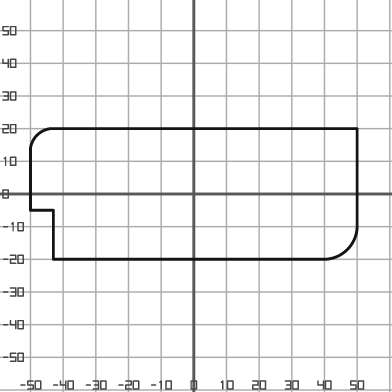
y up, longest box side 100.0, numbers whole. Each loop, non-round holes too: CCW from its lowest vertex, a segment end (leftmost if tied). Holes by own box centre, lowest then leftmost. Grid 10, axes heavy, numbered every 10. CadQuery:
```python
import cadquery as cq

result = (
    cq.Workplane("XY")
    .moveTo(-43.0, -20.0)
    .lineTo(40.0, -20.0)
    .threePointArc((47.0, -17.0), (50.0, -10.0))
    .lineTo(50.0, 20.0)
    .lineTo(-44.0, 20.0)
    .threePointArc((-48.0, 18.0), (-50.0, 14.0))
    .lineTo(-50.0, -5.0)
    .lineTo(-43.0, -5.0)
    .close()
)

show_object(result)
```